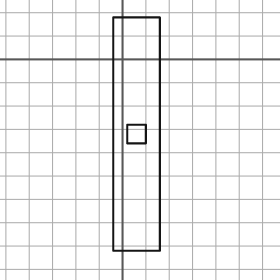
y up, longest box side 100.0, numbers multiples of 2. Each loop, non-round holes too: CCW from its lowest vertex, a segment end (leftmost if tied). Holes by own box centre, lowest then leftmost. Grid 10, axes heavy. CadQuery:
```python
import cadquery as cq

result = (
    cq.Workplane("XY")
    .moveTo(-4.0, -82.0)
    .lineTo(16.0, -82.0)
    .lineTo(16.0, 18.0)
    .lineTo(-4.0, 18.0)
    .close()
    .moveTo(2.0, -36.0)
    .lineTo(10.0, -36.0)
    .lineTo(10.0, -28.0)
    .lineTo(2.0, -28.0)
    .close()
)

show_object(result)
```